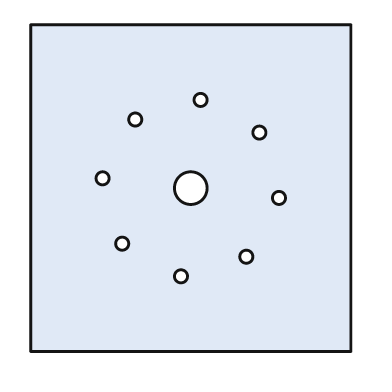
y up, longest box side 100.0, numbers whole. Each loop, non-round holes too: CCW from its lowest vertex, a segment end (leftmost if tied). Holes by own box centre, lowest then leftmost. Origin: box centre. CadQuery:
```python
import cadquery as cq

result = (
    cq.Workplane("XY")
    .moveTo(-49.0, -50.0)
    .lineTo(49.0, -50.0)
    .lineTo(49.0, 50.0)
    .lineTo(-49.0, 50.0)
    .close()
    .moveTo(-3.0, -27.0)
    .circle(2.0)
    .moveTo(17.0, -21.0)
    .circle(2.0)
    .moveTo(-21.0, -17.0)
    .circle(2.0)
    .moveTo(27.0, -3.0)
    .circle(2.0)
    .moveTo(0.0, 0.0)
    .circle(5.0)
    .moveTo(-27.0, 3.0)
    .circle(2.0)
    .moveTo(21.0, 17.0)
    .circle(2.0)
    .moveTo(-17.0, 21.0)
    .circle(2.0)
    .moveTo(3.0, 27.0)
    .circle(2.0)
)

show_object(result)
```